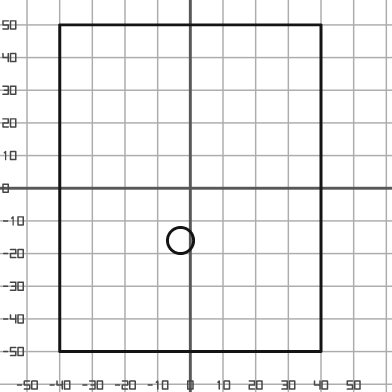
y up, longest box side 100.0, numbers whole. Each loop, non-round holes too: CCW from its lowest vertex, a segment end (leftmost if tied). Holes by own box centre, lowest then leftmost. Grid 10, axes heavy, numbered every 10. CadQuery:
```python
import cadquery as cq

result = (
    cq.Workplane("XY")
    .moveTo(-40.0, -50.0)
    .lineTo(40.0, -50.0)
    .lineTo(40.0, 50.0)
    .lineTo(-40.0, 50.0)
    .close()
    .moveTo(-3.0, -16.0)
    .circle(4.0)
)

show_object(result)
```